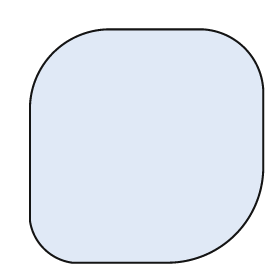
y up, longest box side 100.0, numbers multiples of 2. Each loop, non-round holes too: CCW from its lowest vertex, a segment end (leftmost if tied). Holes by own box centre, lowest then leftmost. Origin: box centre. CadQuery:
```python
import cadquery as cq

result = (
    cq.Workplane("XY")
    .moveTo(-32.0, -50.0)
    .lineTo(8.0, -50.0)
    .threePointArc((38.0, -38.0), (50.0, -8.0))
    .lineTo(50.0, 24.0)
    .threePointArc((42.0, 42.0), (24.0, 50.0))
    .lineTo(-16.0, 50.0)
    .threePointArc((-40.0, 40.0), (-50.0, 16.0))
    .lineTo(-50.0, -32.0)
    .threePointArc((-44.0, -44.0), (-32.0, -50.0))
    .close()
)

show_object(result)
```